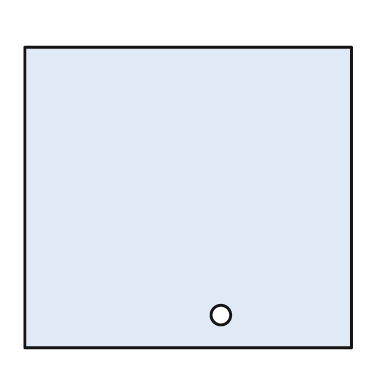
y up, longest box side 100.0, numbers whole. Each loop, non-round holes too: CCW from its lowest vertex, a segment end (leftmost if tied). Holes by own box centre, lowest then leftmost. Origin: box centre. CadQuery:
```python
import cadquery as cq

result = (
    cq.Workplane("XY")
    .moveTo(-50.0, -46.0)
    .lineTo(50.0, -46.0)
    .lineTo(50.0, 46.0)
    .lineTo(-50.0, 46.0)
    .close()
    .moveTo(10.0, -36.0)
    .circle(3.0)
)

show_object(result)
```